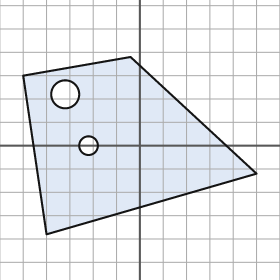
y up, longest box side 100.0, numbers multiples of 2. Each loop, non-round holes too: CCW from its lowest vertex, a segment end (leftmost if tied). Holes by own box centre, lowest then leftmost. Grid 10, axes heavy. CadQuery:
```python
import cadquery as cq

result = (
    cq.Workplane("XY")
    .moveTo(-40.0, -38.0)
    .lineTo(50.0, -12.0)
    .lineTo(-4.0, 38.0)
    .lineTo(-50.0, 30.0)
    .close()
    .moveTo(-22.0, 0.0)
    .circle(4.0)
    .moveTo(-32.0, 22.0)
    .circle(6.0)
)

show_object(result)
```